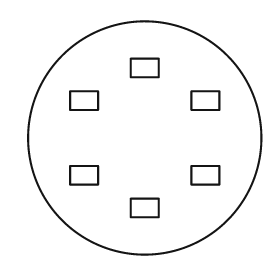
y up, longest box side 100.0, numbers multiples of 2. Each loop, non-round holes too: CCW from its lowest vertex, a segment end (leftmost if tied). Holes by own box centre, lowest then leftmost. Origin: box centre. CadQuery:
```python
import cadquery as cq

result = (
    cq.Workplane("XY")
    .moveTo(0.0, 0.0)
    .circle(50.0)
    .moveTo(-6.0, -34.0)
    .lineTo(6.0, -34.0)
    .lineTo(6.0, -26.0)
    .lineTo(-6.0, -26.0)
    .close()
    .moveTo(-32.0, -20.0)
    .lineTo(-20.0, -20.0)
    .lineTo(-20.0, -12.0)
    .lineTo(-32.0, -12.0)
    .close()
    .moveTo(20.0, -20.0)
    .lineTo(32.0, -20.0)
    .lineTo(32.0, -12.0)
    .lineTo(20.0, -12.0)
    .close()
    .moveTo(-32.0, 12.0)
    .lineTo(-20.0, 12.0)
    .lineTo(-20.0, 20.0)
    .lineTo(-32.0, 20.0)
    .close()
    .moveTo(20.0, 12.0)
    .lineTo(32.0, 12.0)
    .lineTo(32.0, 20.0)
    .lineTo(20.0, 20.0)
    .close()
    .moveTo(-6.0, 26.0)
    .lineTo(6.0, 26.0)
    .lineTo(6.0, 34.0)
    .lineTo(-6.0, 34.0)
    .close()
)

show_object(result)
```